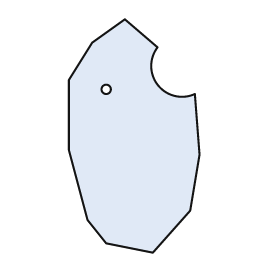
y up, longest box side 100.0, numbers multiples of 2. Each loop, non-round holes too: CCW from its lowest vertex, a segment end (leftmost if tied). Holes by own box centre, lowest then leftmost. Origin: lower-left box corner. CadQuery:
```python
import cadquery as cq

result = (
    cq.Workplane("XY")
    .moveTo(36.0, 0.0)
    .lineTo(52.0, 18.0)
    .lineTo(56.0, 42.0)
    .lineTo(54.0, 68.0)
    .threePointArc((38.0, 72.0), (38.0, 88.0))
    .lineTo(24.0, 100.0)
    .lineTo(10.0, 90.0)
    .lineTo(0.0, 74.0)
    .lineTo(0.0, 44.0)
    .lineTo(8.0, 14.0)
    .lineTo(16.0, 4.0)
    .close()
    .moveTo(16.0, 70.0)
    .circle(2.0)
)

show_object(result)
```